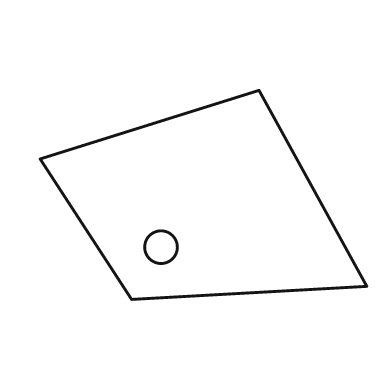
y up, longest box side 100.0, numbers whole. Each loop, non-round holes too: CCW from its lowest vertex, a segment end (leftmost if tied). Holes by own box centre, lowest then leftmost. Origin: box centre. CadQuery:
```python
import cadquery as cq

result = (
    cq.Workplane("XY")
    .moveTo(-22.0, -32.0)
    .lineTo(50.0, -28.0)
    .lineTo(17.0, 32.0)
    .lineTo(-50.0, 11.0)
    .close()
    .moveTo(-13.0, -16.0)
    .circle(5.0)
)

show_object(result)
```